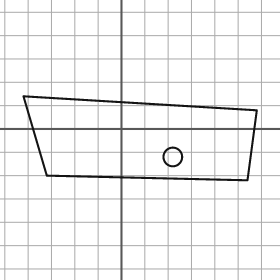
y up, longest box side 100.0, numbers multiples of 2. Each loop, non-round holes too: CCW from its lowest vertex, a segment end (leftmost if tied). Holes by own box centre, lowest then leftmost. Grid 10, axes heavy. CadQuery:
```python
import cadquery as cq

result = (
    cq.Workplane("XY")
    .moveTo(54.0, -22.0)
    .lineTo(58.0, 8.0)
    .lineTo(-42.0, 14.0)
    .lineTo(-32.0, -20.0)
    .close()
    .moveTo(22.0, -12.0)
    .circle(4.0)
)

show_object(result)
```